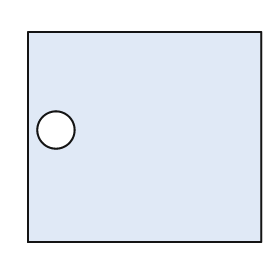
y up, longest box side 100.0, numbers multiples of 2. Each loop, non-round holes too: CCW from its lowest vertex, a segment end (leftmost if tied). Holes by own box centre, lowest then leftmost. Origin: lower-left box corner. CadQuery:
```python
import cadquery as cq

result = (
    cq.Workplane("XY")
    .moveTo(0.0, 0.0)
    .lineTo(100.0, 0.0)
    .lineTo(100.0, 90.0)
    .lineTo(0.0, 90.0)
    .close()
    .moveTo(12.0, 48.0)
    .circle(8.0)
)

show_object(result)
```